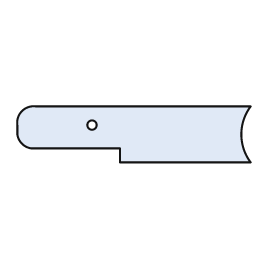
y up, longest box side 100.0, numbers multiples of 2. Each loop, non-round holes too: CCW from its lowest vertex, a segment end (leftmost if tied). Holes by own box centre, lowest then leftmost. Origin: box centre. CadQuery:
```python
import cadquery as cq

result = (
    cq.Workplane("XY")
    .moveTo(-6.0, -12.0)
    .lineTo(50.0, -12.0)
    .threePointArc((46.0, 0.0), (50.0, 12.0))
    .lineTo(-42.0, 12.0)
    .threePointArc((-48.0, 10.0), (-50.0, 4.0))
    .lineTo(-50.0, 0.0)
    .threePointArc((-48.0, -4.0), (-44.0, -6.0))
    .lineTo(-6.0, -6.0)
    .close()
    .moveTo(-18.0, 4.0)
    .circle(2.0)
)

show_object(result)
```